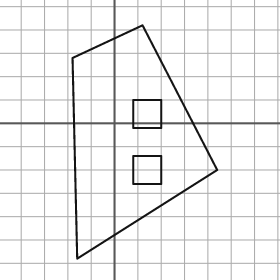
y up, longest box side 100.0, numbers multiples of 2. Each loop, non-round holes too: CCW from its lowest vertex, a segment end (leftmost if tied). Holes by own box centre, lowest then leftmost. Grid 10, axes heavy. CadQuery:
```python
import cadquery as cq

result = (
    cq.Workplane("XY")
    .moveTo(-16.0, -58.0)
    .lineTo(44.0, -20.0)
    .lineTo(12.0, 42.0)
    .lineTo(-18.0, 28.0)
    .close()
    .moveTo(8.0, -26.0)
    .lineTo(20.0, -26.0)
    .lineTo(20.0, -14.0)
    .lineTo(8.0, -14.0)
    .close()
    .moveTo(8.0, -2.0)
    .lineTo(20.0, -2.0)
    .lineTo(20.0, 10.0)
    .lineTo(8.0, 10.0)
    .close()
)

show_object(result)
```